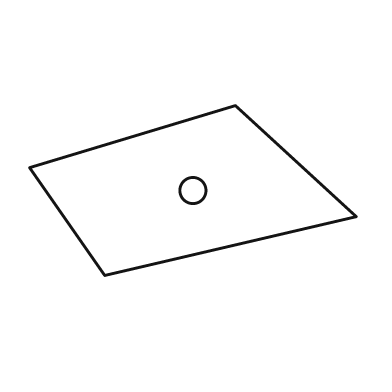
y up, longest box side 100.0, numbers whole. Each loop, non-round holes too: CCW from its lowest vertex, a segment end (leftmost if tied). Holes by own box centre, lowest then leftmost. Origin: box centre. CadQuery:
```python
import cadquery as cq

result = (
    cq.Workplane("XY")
    .moveTo(-27.0, -26.0)
    .lineTo(50.0, -8.0)
    .lineTo(13.0, 26.0)
    .lineTo(-50.0, 7.0)
    .close()
    .moveTo(0.0, 0.0)
    .circle(4.0)
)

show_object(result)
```